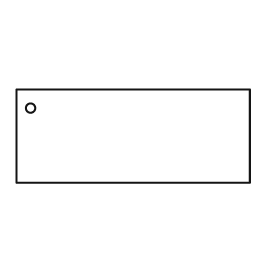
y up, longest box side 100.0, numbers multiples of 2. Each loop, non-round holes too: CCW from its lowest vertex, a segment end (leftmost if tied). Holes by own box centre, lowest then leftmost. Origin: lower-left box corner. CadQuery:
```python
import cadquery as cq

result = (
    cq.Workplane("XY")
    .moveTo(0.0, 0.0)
    .lineTo(100.0, 0.0)
    .lineTo(100.0, 40.0)
    .lineTo(0.0, 40.0)
    .close()
    .moveTo(6.0, 32.0)
    .circle(2.0)
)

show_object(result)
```